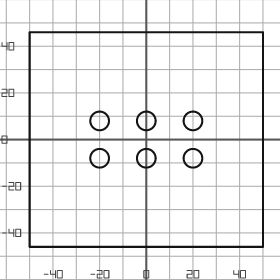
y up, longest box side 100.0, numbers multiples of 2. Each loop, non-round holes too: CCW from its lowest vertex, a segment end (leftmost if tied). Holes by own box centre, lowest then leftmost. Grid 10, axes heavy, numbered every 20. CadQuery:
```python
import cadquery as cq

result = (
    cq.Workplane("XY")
    .moveTo(-50.0, -46.0)
    .lineTo(50.0, -46.0)
    .lineTo(50.0, 46.0)
    .lineTo(-50.0, 46.0)
    .close()
    .moveTo(-20.0, -8.0)
    .circle(4.0)
    .moveTo(0.0, -8.0)
    .circle(4.0)
    .moveTo(20.0, -8.0)
    .circle(4.0)
    .moveTo(-20.0, 8.0)
    .circle(4.0)
    .moveTo(0.0, 8.0)
    .circle(4.0)
    .moveTo(20.0, 8.0)
    .circle(4.0)
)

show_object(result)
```